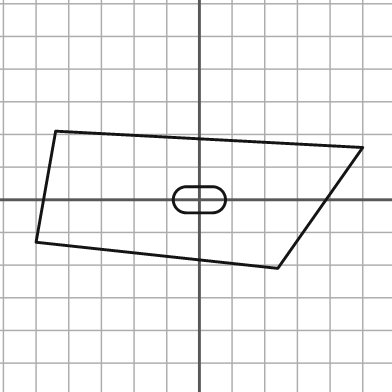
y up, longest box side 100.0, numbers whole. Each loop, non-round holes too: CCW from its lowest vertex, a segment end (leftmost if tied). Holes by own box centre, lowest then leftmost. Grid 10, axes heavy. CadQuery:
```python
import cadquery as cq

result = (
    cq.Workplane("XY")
    .moveTo(24.0, -21.0)
    .lineTo(50.0, 16.0)
    .lineTo(-44.0, 21.0)
    .lineTo(-50.0, -13.0)
    .close()
    .moveTo(-4.0, -4.0)
    .lineTo(4.0, -4.0)
    .threePointArc((8.0, 0.0), (4.0, 4.0))
    .lineTo(-4.0, 4.0)
    .threePointArc((-8.0, 0.0), (-4.0, -4.0))
    .close()
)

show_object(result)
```